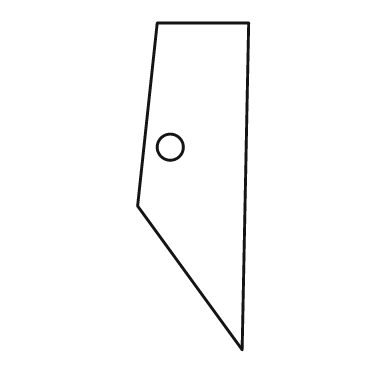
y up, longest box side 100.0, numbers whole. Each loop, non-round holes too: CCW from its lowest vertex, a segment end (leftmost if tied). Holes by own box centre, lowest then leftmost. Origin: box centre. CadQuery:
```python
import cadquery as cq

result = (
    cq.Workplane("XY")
    .moveTo(15.0, -50.0)
    .lineTo(17.0, 50.0)
    .lineTo(-11.0, 50.0)
    .lineTo(-17.0, -6.0)
    .close()
    .moveTo(-7.0, 12.0)
    .circle(4.0)
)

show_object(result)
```